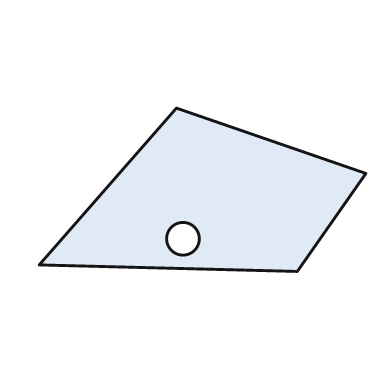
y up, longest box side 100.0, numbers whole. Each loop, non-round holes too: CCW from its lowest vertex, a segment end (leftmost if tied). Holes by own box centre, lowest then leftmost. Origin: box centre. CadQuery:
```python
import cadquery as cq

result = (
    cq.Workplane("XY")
    .moveTo(29.0, -25.0)
    .lineTo(50.0, 5.0)
    .lineTo(-8.0, 25.0)
    .lineTo(-50.0, -23.0)
    .close()
    .moveTo(-6.0, -15.0)
    .circle(5.0)
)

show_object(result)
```